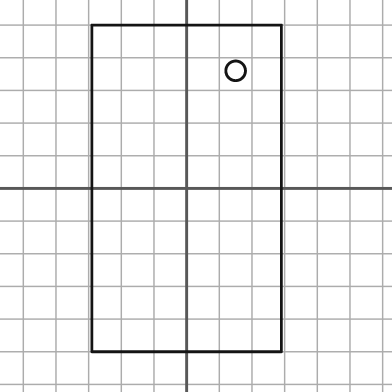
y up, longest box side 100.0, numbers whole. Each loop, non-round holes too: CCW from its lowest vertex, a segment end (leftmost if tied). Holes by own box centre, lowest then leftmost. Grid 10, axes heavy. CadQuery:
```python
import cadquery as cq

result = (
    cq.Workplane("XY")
    .moveTo(-29.0, -50.0)
    .lineTo(29.0, -50.0)
    .lineTo(29.0, 50.0)
    .lineTo(-29.0, 50.0)
    .close()
    .moveTo(15.0, 36.0)
    .circle(3.0)
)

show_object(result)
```